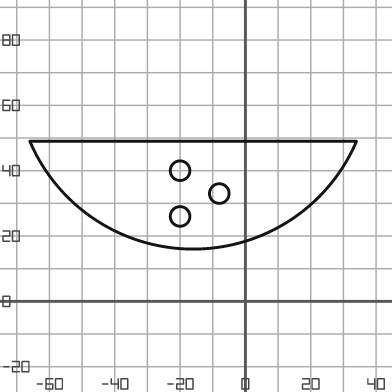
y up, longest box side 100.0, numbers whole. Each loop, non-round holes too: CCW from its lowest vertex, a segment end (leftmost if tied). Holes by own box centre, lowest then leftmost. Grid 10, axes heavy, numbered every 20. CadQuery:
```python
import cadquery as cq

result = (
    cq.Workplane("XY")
    .moveTo(-66.0, 49.0)
    .threePointArc((-16.0, 16.0), (34.0, 49.0))
    .close()
    .moveTo(-20.0, 26.0)
    .circle(3.0)
    .moveTo(-8.0, 33.0)
    .circle(3.0)
    .moveTo(-20.0, 40.0)
    .circle(3.0)
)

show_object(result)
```